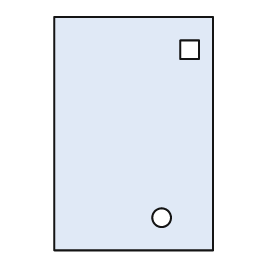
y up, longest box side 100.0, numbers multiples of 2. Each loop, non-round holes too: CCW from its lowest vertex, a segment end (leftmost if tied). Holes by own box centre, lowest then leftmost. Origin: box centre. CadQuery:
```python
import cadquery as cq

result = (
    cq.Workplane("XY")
    .moveTo(-34.0, -50.0)
    .lineTo(34.0, -50.0)
    .lineTo(34.0, 50.0)
    .lineTo(-34.0, 50.0)
    .close()
    .moveTo(12.0, -36.0)
    .circle(4.0)
    .moveTo(20.0, 32.0)
    .lineTo(28.0, 32.0)
    .lineTo(28.0, 40.0)
    .lineTo(20.0, 40.0)
    .close()
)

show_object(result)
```